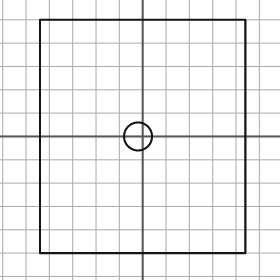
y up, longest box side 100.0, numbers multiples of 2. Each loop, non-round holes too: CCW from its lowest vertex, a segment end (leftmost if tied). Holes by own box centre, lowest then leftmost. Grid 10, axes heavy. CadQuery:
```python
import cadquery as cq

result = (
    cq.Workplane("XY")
    .moveTo(-44.0, -50.0)
    .lineTo(44.0, -50.0)
    .lineTo(44.0, 50.0)
    .lineTo(-44.0, 50.0)
    .close()
    .moveTo(-2.0, 0.0)
    .circle(6.0)
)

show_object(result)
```